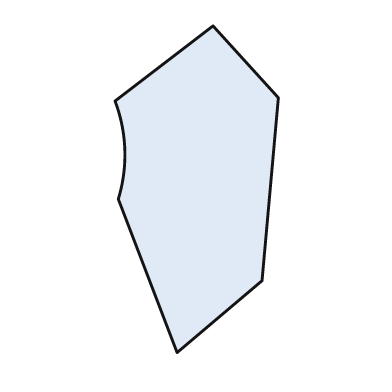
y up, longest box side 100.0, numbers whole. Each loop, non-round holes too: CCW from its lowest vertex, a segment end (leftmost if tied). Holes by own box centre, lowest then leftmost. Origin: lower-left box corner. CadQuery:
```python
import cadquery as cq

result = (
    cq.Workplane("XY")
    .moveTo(19.0, 0.0)
    .lineTo(45.0, 22.0)
    .lineTo(50.0, 78.0)
    .lineTo(30.0, 100.0)
    .lineTo(0.0, 77.0)
    .threePointArc((3.0, 62.0), (1.0, 47.0))
    .close()
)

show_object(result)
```